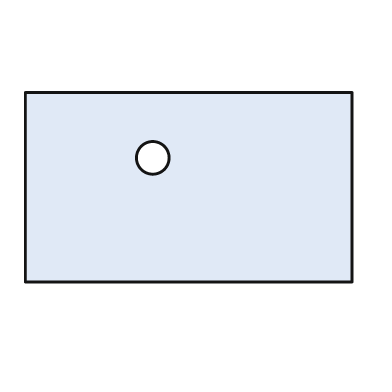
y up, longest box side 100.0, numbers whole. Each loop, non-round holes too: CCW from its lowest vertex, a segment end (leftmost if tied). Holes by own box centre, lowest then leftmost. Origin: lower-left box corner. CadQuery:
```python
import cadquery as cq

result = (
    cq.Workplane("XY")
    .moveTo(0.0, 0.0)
    .lineTo(100.0, 0.0)
    .lineTo(100.0, 58.0)
    .lineTo(0.0, 58.0)
    .close()
    .moveTo(39.0, 38.0)
    .circle(5.0)
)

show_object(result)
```